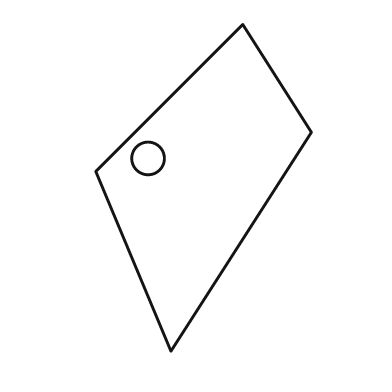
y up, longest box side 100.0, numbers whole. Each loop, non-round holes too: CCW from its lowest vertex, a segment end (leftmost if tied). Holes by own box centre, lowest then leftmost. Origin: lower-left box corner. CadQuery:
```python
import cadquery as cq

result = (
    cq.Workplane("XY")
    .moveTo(23.0, 0.0)
    .lineTo(66.0, 67.0)
    .lineTo(45.0, 100.0)
    .lineTo(0.0, 55.0)
    .close()
    .moveTo(16.0, 59.0)
    .circle(5.0)
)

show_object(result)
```